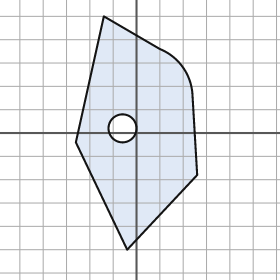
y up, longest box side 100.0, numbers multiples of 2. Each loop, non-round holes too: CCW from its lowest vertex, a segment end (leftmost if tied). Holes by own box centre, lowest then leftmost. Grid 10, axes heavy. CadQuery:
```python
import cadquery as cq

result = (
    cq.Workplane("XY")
    .moveTo(-4.0, -50.0)
    .lineTo(26.0, -18.0)
    .lineTo(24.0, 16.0)
    .threePointArc((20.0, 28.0), (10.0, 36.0))
    .lineTo(-14.0, 50.0)
    .lineTo(-26.0, -4.0)
    .close()
    .moveTo(-6.0, 2.0)
    .circle(6.0)
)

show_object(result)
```